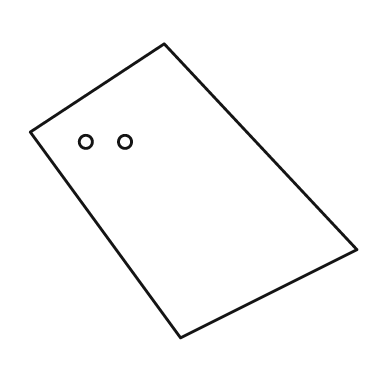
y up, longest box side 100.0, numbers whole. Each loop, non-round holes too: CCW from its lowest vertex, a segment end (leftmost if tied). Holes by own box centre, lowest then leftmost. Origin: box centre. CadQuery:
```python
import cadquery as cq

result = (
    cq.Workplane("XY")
    .moveTo(-4.0, -45.0)
    .lineTo(50.0, -18.0)
    .lineTo(-9.0, 45.0)
    .lineTo(-50.0, 18.0)
    .close()
    .moveTo(-33.0, 15.0)
    .circle(2.0)
    .moveTo(-21.0, 15.0)
    .circle(2.0)
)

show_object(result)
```